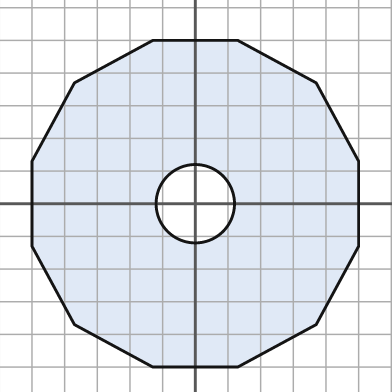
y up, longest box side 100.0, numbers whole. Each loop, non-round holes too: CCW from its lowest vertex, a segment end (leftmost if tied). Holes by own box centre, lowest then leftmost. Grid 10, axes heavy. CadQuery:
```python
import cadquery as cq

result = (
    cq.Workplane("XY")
    .moveTo(-13.0, -50.0)
    .lineTo(13.0, -50.0)
    .lineTo(37.0, -37.0)
    .lineTo(50.0, -13.0)
    .lineTo(50.0, 13.0)
    .lineTo(37.0, 37.0)
    .lineTo(13.0, 50.0)
    .lineTo(-13.0, 50.0)
    .lineTo(-37.0, 37.0)
    .lineTo(-50.0, 13.0)
    .lineTo(-50.0, -13.0)
    .lineTo(-37.0, -37.0)
    .close()
    .moveTo(0.0, 0.0)
    .circle(12.0)
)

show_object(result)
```